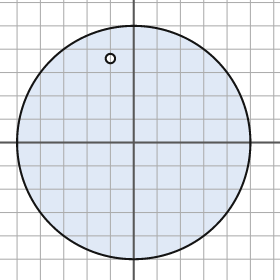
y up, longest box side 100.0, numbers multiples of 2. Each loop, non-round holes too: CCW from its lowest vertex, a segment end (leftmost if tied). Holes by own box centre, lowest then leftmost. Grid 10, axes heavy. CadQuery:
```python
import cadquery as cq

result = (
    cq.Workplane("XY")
    .moveTo(0.0, 0.0)
    .circle(50.0)
    .moveTo(-10.0, 36.0)
    .circle(2.0)
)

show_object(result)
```